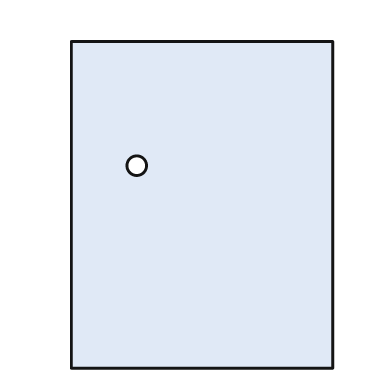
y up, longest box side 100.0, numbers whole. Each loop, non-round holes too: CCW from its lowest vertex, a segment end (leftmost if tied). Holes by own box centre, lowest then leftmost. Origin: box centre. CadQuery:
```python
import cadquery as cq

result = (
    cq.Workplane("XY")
    .moveTo(-40.0, -50.0)
    .lineTo(40.0, -50.0)
    .lineTo(40.0, 50.0)
    .lineTo(-40.0, 50.0)
    .close()
    .moveTo(-20.0, 12.0)
    .circle(3.0)
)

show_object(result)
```